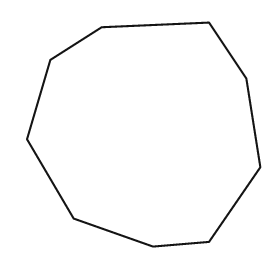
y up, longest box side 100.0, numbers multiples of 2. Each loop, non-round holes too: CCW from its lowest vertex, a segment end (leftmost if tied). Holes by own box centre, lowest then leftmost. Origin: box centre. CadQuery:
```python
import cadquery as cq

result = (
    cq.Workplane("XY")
    .moveTo(4.0, -48.0)
    .lineTo(28.0, -46.0)
    .lineTo(50.0, -14.0)
    .lineTo(44.0, 24.0)
    .lineTo(28.0, 48.0)
    .lineTo(-18.0, 46.0)
    .lineTo(-40.0, 32.0)
    .lineTo(-50.0, -2.0)
    .lineTo(-30.0, -36.0)
    .close()
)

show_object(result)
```